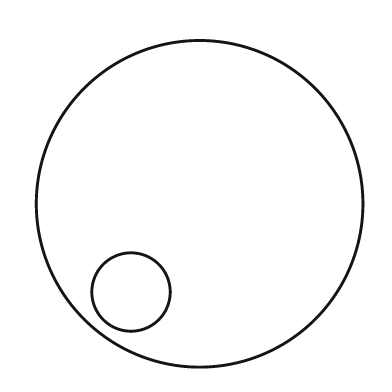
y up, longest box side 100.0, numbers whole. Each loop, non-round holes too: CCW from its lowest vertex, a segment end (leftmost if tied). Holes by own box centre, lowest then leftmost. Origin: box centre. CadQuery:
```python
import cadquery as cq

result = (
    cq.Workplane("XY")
    .moveTo(0.0, 0.0)
    .circle(50.0)
    .moveTo(-21.0, -27.0)
    .circle(12.0)
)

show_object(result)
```